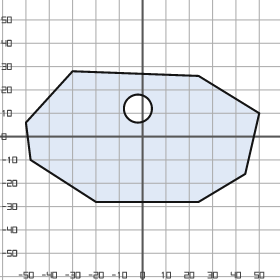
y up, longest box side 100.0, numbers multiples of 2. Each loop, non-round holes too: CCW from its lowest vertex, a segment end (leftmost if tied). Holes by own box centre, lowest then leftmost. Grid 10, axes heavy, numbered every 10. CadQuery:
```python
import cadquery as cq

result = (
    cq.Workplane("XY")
    .moveTo(-20.0, -28.0)
    .lineTo(24.0, -28.0)
    .lineTo(44.0, -16.0)
    .lineTo(50.0, 10.0)
    .lineTo(24.0, 26.0)
    .lineTo(-30.0, 28.0)
    .lineTo(-50.0, 6.0)
    .lineTo(-48.0, -10.0)
    .close()
    .moveTo(-2.0, 12.0)
    .circle(6.0)
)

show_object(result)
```